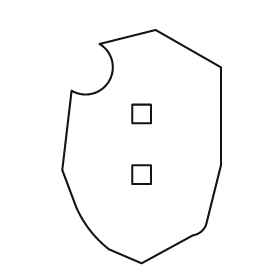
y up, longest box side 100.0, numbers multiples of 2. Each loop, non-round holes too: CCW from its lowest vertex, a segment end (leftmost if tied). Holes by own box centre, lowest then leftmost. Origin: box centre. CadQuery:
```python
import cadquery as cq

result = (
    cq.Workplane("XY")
    .moveTo(0.0, -50.0)
    .lineTo(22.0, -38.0)
    .threePointArc((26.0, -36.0), (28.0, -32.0))
    .lineTo(34.0, -8.0)
    .lineTo(34.0, 34.0)
    .lineTo(6.0, 50.0)
    .lineTo(-18.0, 44.0)
    .threePointArc((-14.0, 28.0), (-30.0, 24.0))
    .lineTo(-34.0, -10.0)
    .lineTo(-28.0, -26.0)
    .threePointArc((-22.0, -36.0), (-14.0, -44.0))
    .close()
    .moveTo(-4.0, -16.0)
    .lineTo(4.0, -16.0)
    .lineTo(4.0, -8.0)
    .lineTo(-4.0, -8.0)
    .close()
    .moveTo(-4.0, 10.0)
    .lineTo(4.0, 10.0)
    .lineTo(4.0, 18.0)
    .lineTo(-4.0, 18.0)
    .close()
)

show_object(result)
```